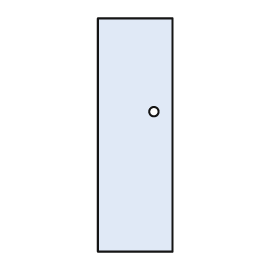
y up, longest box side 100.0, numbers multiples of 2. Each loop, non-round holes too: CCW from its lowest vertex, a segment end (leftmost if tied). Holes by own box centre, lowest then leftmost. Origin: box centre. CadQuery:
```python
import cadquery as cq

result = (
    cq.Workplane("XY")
    .moveTo(-16.0, -50.0)
    .lineTo(16.0, -50.0)
    .lineTo(16.0, 50.0)
    .lineTo(-16.0, 50.0)
    .close()
    .moveTo(8.0, 10.0)
    .circle(2.0)
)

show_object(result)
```